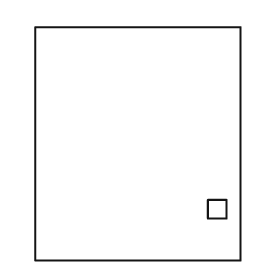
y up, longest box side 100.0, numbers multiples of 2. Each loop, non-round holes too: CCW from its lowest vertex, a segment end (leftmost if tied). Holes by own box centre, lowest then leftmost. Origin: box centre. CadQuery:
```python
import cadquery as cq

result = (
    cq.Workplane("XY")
    .moveTo(-44.0, -50.0)
    .lineTo(44.0, -50.0)
    .lineTo(44.0, 50.0)
    .lineTo(-44.0, 50.0)
    .close()
    .moveTo(30.0, -32.0)
    .lineTo(38.0, -32.0)
    .lineTo(38.0, -24.0)
    .lineTo(30.0, -24.0)
    .close()
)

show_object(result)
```